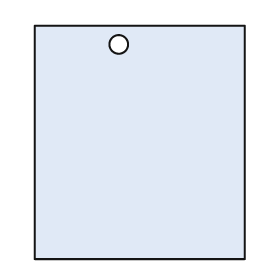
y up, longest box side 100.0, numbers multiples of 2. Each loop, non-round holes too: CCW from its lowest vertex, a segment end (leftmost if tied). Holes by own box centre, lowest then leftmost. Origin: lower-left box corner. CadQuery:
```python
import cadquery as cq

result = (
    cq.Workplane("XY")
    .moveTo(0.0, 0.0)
    .lineTo(90.0, 0.0)
    .lineTo(90.0, 100.0)
    .lineTo(0.0, 100.0)
    .close()
    .moveTo(36.0, 92.0)
    .circle(4.0)
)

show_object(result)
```